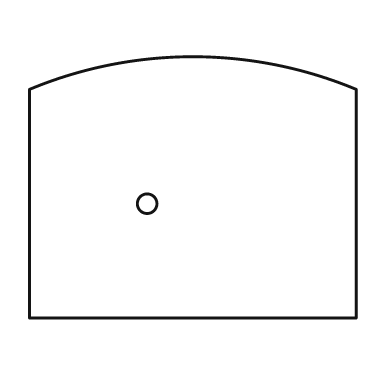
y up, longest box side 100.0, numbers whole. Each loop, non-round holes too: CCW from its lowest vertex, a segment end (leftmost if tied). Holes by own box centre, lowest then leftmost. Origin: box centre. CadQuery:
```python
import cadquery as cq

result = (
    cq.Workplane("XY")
    .moveTo(-50.0, -40.0)
    .lineTo(50.0, -40.0)
    .lineTo(50.0, 30.0)
    .threePointArc((0.0, 40.0), (-50.0, 30.0))
    .close()
    .moveTo(-14.0, -5.0)
    .circle(3.0)
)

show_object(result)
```